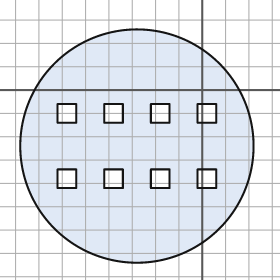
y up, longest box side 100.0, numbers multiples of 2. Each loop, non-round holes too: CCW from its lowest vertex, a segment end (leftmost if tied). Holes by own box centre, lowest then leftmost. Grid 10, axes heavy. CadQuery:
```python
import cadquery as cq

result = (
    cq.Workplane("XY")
    .moveTo(-28.0, -24.0)
    .circle(50.0)
    .moveTo(-62.0, -42.0)
    .lineTo(-54.0, -42.0)
    .lineTo(-54.0, -34.0)
    .lineTo(-62.0, -34.0)
    .close()
    .moveTo(-42.0, -42.0)
    .lineTo(-34.0, -42.0)
    .lineTo(-34.0, -34.0)
    .lineTo(-42.0, -34.0)
    .close()
    .moveTo(-22.0, -42.0)
    .lineTo(-14.0, -42.0)
    .lineTo(-14.0, -34.0)
    .lineTo(-22.0, -34.0)
    .close()
    .moveTo(-2.0, -42.0)
    .lineTo(6.0, -42.0)
    .lineTo(6.0, -34.0)
    .lineTo(-2.0, -34.0)
    .close()
    .moveTo(-62.0, -14.0)
    .lineTo(-54.0, -14.0)
    .lineTo(-54.0, -6.0)
    .lineTo(-62.0, -6.0)
    .close()
    .moveTo(-42.0, -14.0)
    .lineTo(-34.0, -14.0)
    .lineTo(-34.0, -6.0)
    .lineTo(-42.0, -6.0)
    .close()
    .moveTo(-22.0, -14.0)
    .lineTo(-14.0, -14.0)
    .lineTo(-14.0, -6.0)
    .lineTo(-22.0, -6.0)
    .close()
    .moveTo(-2.0, -14.0)
    .lineTo(6.0, -14.0)
    .lineTo(6.0, -6.0)
    .lineTo(-2.0, -6.0)
    .close()
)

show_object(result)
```